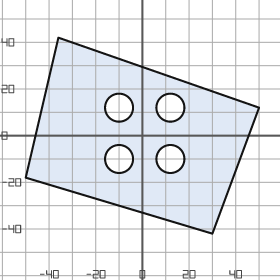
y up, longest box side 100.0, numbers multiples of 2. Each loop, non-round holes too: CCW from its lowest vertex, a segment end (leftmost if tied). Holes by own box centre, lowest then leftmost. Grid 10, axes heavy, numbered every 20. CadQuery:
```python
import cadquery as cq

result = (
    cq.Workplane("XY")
    .moveTo(30.0, -42.0)
    .lineTo(50.0, 12.0)
    .lineTo(-36.0, 42.0)
    .lineTo(-50.0, -18.0)
    .close()
    .moveTo(-10.0, -10.0)
    .circle(6.0)
    .moveTo(12.0, -10.0)
    .circle(6.0)
    .moveTo(-10.0, 12.0)
    .circle(6.0)
    .moveTo(12.0, 12.0)
    .circle(6.0)
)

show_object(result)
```